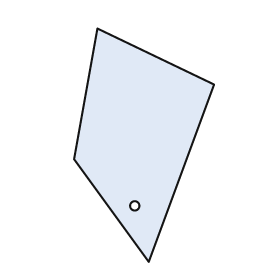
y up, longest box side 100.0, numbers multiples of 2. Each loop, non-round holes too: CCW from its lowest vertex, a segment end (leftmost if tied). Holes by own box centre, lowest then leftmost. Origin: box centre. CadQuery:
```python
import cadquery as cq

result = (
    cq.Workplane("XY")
    .moveTo(2.0, -50.0)
    .lineTo(30.0, 26.0)
    .lineTo(-20.0, 50.0)
    .lineTo(-30.0, -6.0)
    .close()
    .moveTo(-4.0, -26.0)
    .circle(2.0)
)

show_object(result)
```